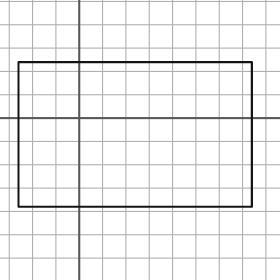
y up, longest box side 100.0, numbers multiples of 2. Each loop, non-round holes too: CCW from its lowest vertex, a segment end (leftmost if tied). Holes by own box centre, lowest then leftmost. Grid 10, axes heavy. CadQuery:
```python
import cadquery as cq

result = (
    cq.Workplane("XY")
    .moveTo(-26.0, -38.0)
    .lineTo(74.0, -38.0)
    .lineTo(74.0, 24.0)
    .lineTo(-26.0, 24.0)
    .close()
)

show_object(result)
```